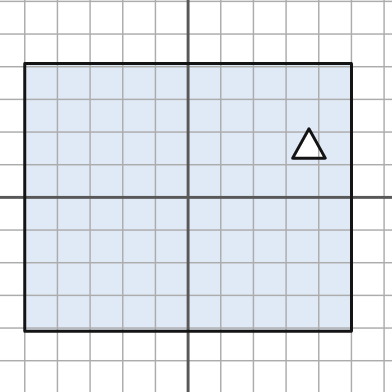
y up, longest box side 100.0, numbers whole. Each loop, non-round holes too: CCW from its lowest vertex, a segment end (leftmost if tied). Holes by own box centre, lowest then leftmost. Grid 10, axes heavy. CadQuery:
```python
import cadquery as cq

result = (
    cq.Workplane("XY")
    .moveTo(-50.0, -41.0)
    .lineTo(50.0, -41.0)
    .lineTo(50.0, 41.0)
    .lineTo(-50.0, 41.0)
    .close()
    .moveTo(32.0, 12.0)
    .lineTo(42.0, 12.0)
    .lineTo(37.0, 21.0)
    .close()
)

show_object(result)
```